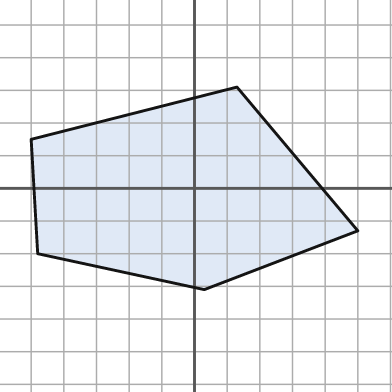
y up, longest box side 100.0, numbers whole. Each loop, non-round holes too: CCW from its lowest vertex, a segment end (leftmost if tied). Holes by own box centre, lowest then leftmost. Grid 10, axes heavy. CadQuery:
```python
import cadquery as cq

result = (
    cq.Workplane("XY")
    .moveTo(3.0, -31.0)
    .lineTo(50.0, -13.0)
    .lineTo(13.0, 31.0)
    .lineTo(-50.0, 15.0)
    .lineTo(-48.0, -20.0)
    .close()
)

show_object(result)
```